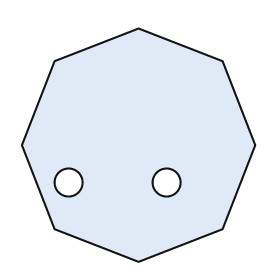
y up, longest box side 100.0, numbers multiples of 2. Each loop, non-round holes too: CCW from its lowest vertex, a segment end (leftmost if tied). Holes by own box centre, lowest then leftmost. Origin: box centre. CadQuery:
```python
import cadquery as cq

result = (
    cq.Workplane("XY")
    .moveTo(0.0, -50.0)
    .lineTo(36.0, -36.0)
    .lineTo(50.0, 0.0)
    .lineTo(36.0, 36.0)
    .lineTo(0.0, 50.0)
    .lineTo(-36.0, 36.0)
    .lineTo(-50.0, 0.0)
    .lineTo(-36.0, -36.0)
    .close()
    .moveTo(-30.0, -16.0)
    .circle(6.0)
    .moveTo(12.0, -16.0)
    .circle(6.0)
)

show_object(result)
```